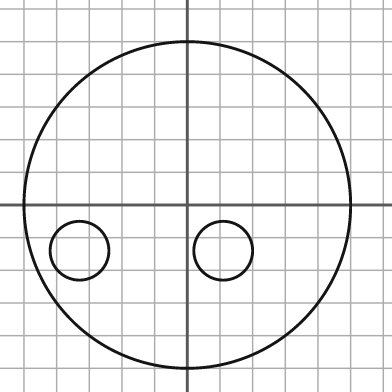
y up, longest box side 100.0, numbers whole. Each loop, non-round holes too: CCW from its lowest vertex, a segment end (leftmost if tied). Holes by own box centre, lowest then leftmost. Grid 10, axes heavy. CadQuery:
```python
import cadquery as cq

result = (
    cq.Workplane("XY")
    .moveTo(0.0, 0.0)
    .circle(50.0)
    .moveTo(-33.0, -14.0)
    .circle(9.0)
    .moveTo(11.0, -14.0)
    .circle(9.0)
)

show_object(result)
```